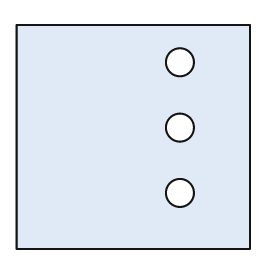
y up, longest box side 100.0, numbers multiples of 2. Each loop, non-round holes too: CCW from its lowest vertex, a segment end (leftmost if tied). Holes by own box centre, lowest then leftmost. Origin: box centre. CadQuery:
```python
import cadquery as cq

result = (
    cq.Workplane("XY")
    .moveTo(-50.0, -48.0)
    .lineTo(50.0, -48.0)
    .lineTo(50.0, 48.0)
    .lineTo(-50.0, 48.0)
    .close()
    .moveTo(20.0, -24.0)
    .circle(6.0)
    .moveTo(20.0, 4.0)
    .circle(6.0)
    .moveTo(20.0, 32.0)
    .circle(6.0)
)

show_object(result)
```